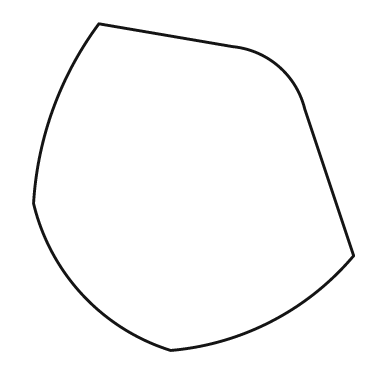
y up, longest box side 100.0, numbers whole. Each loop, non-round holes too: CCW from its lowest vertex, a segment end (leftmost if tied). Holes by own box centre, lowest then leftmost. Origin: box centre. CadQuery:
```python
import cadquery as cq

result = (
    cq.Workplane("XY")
    .moveTo(-7.0, -50.0)
    .threePointArc((24.0, -41.0), (49.0, -21.0))
    .lineTo(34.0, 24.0)
    .threePointArc((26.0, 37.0), (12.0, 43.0))
    .lineTo(-29.0, 50.0)
    .threePointArc((-43.0, 24.0), (-49.0, -5.0))
    .threePointArc((-34.0, -33.0), (-7.0, -50.0))
    .close()
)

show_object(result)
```